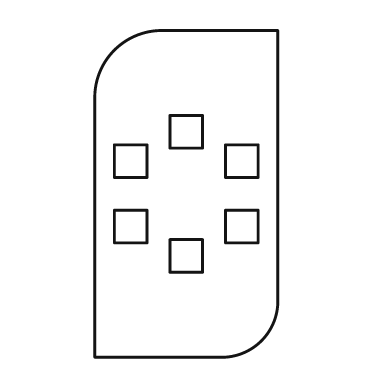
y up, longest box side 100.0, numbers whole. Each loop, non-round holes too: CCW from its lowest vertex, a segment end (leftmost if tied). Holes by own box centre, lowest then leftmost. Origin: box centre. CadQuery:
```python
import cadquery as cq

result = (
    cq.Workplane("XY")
    .moveTo(-28.0, -50.0)
    .lineTo(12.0, -50.0)
    .threePointArc((23.0, -45.0), (28.0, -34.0))
    .lineTo(28.0, 50.0)
    .lineTo(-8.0, 50.0)
    .threePointArc((-22.0, 44.0), (-28.0, 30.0))
    .close()
    .moveTo(-5.0, -24.0)
    .lineTo(5.0, -24.0)
    .lineTo(5.0, -14.0)
    .lineTo(-5.0, -14.0)
    .close()
    .moveTo(-22.0, -15.0)
    .lineTo(-12.0, -15.0)
    .lineTo(-12.0, -5.0)
    .lineTo(-22.0, -5.0)
    .close()
    .moveTo(12.0, -15.0)
    .lineTo(22.0, -15.0)
    .lineTo(22.0, -5.0)
    .lineTo(12.0, -5.0)
    .close()
    .moveTo(-22.0, 5.0)
    .lineTo(-12.0, 5.0)
    .lineTo(-12.0, 15.0)
    .lineTo(-22.0, 15.0)
    .close()
    .moveTo(12.0, 5.0)
    .lineTo(22.0, 5.0)
    .lineTo(22.0, 15.0)
    .lineTo(12.0, 15.0)
    .close()
    .moveTo(-5.0, 14.0)
    .lineTo(5.0, 14.0)
    .lineTo(5.0, 24.0)
    .lineTo(-5.0, 24.0)
    .close()
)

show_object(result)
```